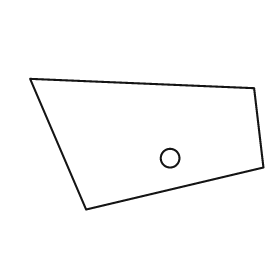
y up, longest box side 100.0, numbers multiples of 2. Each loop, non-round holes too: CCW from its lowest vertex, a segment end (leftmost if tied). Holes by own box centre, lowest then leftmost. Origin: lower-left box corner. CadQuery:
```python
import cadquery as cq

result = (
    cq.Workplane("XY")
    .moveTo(24.0, 0.0)
    .lineTo(100.0, 18.0)
    .lineTo(96.0, 52.0)
    .lineTo(0.0, 56.0)
    .close()
    .moveTo(60.0, 22.0)
    .circle(4.0)
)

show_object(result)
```